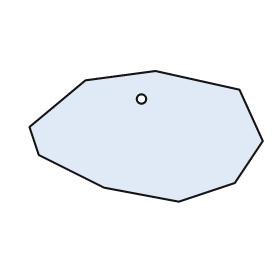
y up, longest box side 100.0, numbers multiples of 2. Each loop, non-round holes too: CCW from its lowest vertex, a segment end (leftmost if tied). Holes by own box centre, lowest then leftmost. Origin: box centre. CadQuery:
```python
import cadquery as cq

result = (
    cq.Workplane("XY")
    .moveTo(14.0, -28.0)
    .lineTo(38.0, -20.0)
    .lineTo(50.0, -2.0)
    .lineTo(40.0, 20.0)
    .lineTo(4.0, 28.0)
    .lineTo(-26.0, 24.0)
    .lineTo(-50.0, 4.0)
    .lineTo(-46.0, -8.0)
    .lineTo(-18.0, -22.0)
    .close()
    .moveTo(-2.0, 16.0)
    .circle(2.0)
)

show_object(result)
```